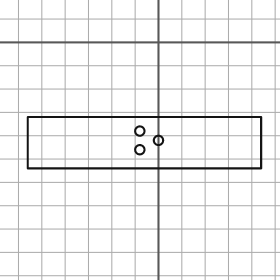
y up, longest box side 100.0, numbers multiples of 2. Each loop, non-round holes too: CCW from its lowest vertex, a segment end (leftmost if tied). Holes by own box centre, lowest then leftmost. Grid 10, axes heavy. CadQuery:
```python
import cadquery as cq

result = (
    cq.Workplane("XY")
    .moveTo(-56.0, -54.0)
    .lineTo(44.0, -54.0)
    .lineTo(44.0, -32.0)
    .lineTo(-56.0, -32.0)
    .close()
    .moveTo(-8.0, -46.0)
    .circle(2.0)
    .moveTo(0.0, -42.0)
    .circle(2.0)
    .moveTo(-8.0, -38.0)
    .circle(2.0)
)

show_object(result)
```